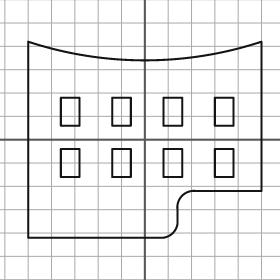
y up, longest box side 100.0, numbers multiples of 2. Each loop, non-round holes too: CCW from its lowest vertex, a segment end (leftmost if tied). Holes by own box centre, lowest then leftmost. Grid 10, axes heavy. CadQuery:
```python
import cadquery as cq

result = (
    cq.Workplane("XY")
    .moveTo(-50.0, -42.0)
    .lineTo(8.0, -42.0)
    .threePointArc((12.0, -40.0), (14.0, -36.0))
    .lineTo(14.0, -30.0)
    .threePointArc((16.0, -24.0), (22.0, -22.0))
    .lineTo(50.0, -22.0)
    .lineTo(50.0, 42.0)
    .threePointArc((0.0, 34.0), (-50.0, 42.0))
    .close()
    .moveTo(-36.0, -16.0)
    .lineTo(-28.0, -16.0)
    .lineTo(-28.0, -4.0)
    .lineTo(-36.0, -4.0)
    .close()
    .moveTo(-14.0, -16.0)
    .lineTo(-6.0, -16.0)
    .lineTo(-6.0, -4.0)
    .lineTo(-14.0, -4.0)
    .close()
    .moveTo(8.0, -16.0)
    .lineTo(16.0, -16.0)
    .lineTo(16.0, -4.0)
    .lineTo(8.0, -4.0)
    .close()
    .moveTo(30.0, -16.0)
    .lineTo(38.0, -16.0)
    .lineTo(38.0, -4.0)
    .lineTo(30.0, -4.0)
    .close()
    .moveTo(-36.0, 6.0)
    .lineTo(-28.0, 6.0)
    .lineTo(-28.0, 18.0)
    .lineTo(-36.0, 18.0)
    .close()
    .moveTo(-14.0, 6.0)
    .lineTo(-6.0, 6.0)
    .lineTo(-6.0, 18.0)
    .lineTo(-14.0, 18.0)
    .close()
    .moveTo(8.0, 6.0)
    .lineTo(16.0, 6.0)
    .lineTo(16.0, 18.0)
    .lineTo(8.0, 18.0)
    .close()
    .moveTo(30.0, 6.0)
    .lineTo(38.0, 6.0)
    .lineTo(38.0, 18.0)
    .lineTo(30.0, 18.0)
    .close()
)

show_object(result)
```